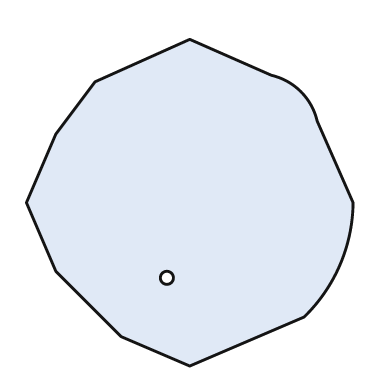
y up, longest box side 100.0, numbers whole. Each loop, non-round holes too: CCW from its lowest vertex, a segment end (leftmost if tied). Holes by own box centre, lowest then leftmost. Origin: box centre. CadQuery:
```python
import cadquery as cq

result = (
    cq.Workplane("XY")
    .moveTo(0.0, -50.0)
    .lineTo(35.0, -35.0)
    .threePointArc((46.0, -19.0), (50.0, 0.0))
    .lineTo(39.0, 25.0)
    .threePointArc((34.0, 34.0), (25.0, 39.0))
    .lineTo(0.0, 50.0)
    .lineTo(-29.0, 37.0)
    .lineTo(-41.0, 21.0)
    .lineTo(-50.0, 0.0)
    .lineTo(-41.0, -21.0)
    .lineTo(-21.0, -41.0)
    .close()
    .moveTo(-7.0, -23.0)
    .circle(2.0)
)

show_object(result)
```